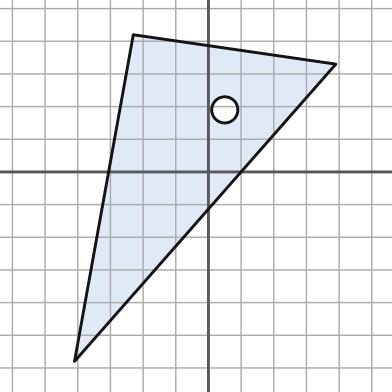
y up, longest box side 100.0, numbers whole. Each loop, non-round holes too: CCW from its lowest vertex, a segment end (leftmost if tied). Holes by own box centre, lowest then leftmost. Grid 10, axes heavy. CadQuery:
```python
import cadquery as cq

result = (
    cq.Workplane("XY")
    .moveTo(-41.0, -58.0)
    .lineTo(39.0, 33.0)
    .lineTo(-23.0, 42.0)
    .close()
    .moveTo(5.0, 19.0)
    .circle(4.0)
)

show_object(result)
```